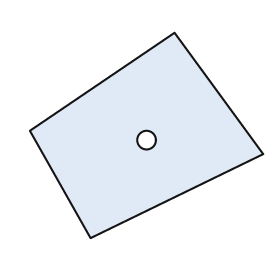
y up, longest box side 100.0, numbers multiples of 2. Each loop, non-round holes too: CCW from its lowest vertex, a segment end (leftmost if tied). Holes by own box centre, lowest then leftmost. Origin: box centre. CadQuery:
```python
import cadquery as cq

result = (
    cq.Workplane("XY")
    .moveTo(-24.0, -44.0)
    .lineTo(50.0, -8.0)
    .lineTo(12.0, 44.0)
    .lineTo(-50.0, 2.0)
    .close()
    .moveTo(0.0, -2.0)
    .circle(4.0)
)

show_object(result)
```